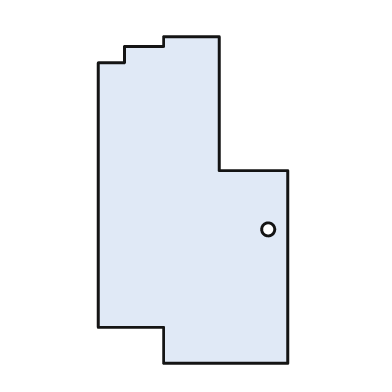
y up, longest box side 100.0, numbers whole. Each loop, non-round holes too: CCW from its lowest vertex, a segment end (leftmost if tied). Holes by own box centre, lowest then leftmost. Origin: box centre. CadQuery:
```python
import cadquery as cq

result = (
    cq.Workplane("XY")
    .moveTo(-9.0, -50.0)
    .lineTo(29.0, -50.0)
    .lineTo(29.0, 9.0)
    .lineTo(8.0, 9.0)
    .lineTo(8.0, 50.0)
    .lineTo(-9.0, 50.0)
    .lineTo(-9.0, 47.0)
    .lineTo(-21.0, 47.0)
    .lineTo(-21.0, 42.0)
    .lineTo(-29.0, 42.0)
    .lineTo(-29.0, -39.0)
    .lineTo(-9.0, -39.0)
    .close()
    .moveTo(23.0, -9.0)
    .circle(2.0)
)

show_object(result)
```